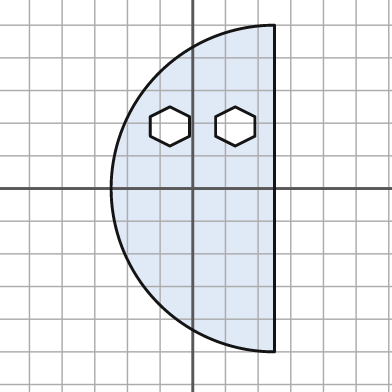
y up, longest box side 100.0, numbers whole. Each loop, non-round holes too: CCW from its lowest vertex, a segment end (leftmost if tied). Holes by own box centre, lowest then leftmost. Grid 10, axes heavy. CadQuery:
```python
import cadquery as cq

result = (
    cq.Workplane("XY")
    .moveTo(25.0, -50.0)
    .lineTo(25.0, 50.0)
    .threePointArc((-25.0, 0.0), (25.0, -50.0))
    .close()
    .moveTo(-7.0, 13.0)
    .lineTo(-1.0, 16.0)
    .lineTo(-1.0, 22.0)
    .lineTo(-7.0, 25.0)
    .lineTo(-13.0, 22.0)
    .lineTo(-13.0, 16.0)
    .close()
    .moveTo(13.0, 13.0)
    .lineTo(19.0, 16.0)
    .lineTo(19.0, 22.0)
    .lineTo(13.0, 25.0)
    .lineTo(7.0, 22.0)
    .lineTo(7.0, 16.0)
    .close()
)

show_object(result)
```